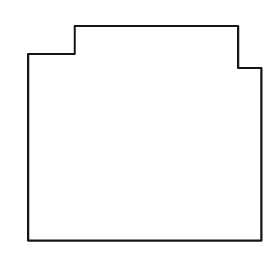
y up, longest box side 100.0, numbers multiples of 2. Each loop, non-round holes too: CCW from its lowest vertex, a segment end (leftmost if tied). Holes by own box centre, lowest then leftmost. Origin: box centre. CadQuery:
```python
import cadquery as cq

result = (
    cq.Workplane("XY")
    .moveTo(-50.0, -46.0)
    .lineTo(50.0, -46.0)
    .lineTo(50.0, 28.0)
    .lineTo(40.0, 28.0)
    .lineTo(40.0, 46.0)
    .lineTo(-30.0, 46.0)
    .lineTo(-30.0, 34.0)
    .lineTo(-50.0, 34.0)
    .close()
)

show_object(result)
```